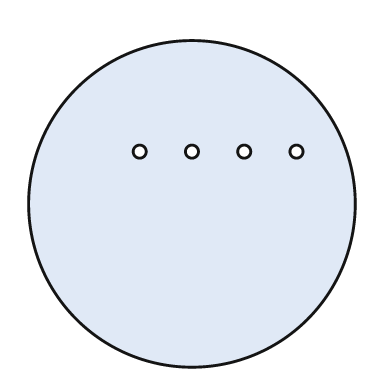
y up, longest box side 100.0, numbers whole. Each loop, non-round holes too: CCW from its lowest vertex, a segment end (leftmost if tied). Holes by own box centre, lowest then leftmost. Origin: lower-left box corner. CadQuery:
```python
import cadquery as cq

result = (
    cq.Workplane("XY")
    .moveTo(50.0, 50.0)
    .circle(50.0)
    .moveTo(34.0, 66.0)
    .circle(2.0)
    .moveTo(50.0, 66.0)
    .circle(2.0)
    .moveTo(66.0, 66.0)
    .circle(2.0)
    .moveTo(82.0, 66.0)
    .circle(2.0)
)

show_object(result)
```